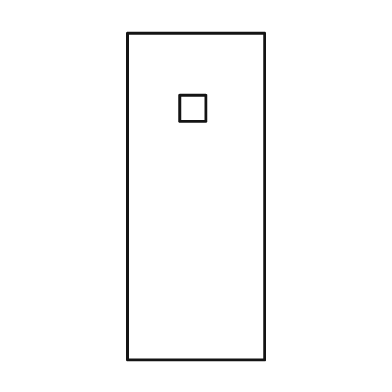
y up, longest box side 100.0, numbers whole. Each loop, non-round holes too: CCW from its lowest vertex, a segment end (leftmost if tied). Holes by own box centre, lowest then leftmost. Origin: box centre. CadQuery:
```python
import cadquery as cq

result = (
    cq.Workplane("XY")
    .moveTo(-21.0, -50.0)
    .lineTo(21.0, -50.0)
    .lineTo(21.0, 50.0)
    .lineTo(-21.0, 50.0)
    .close()
    .moveTo(-5.0, 23.0)
    .lineTo(3.0, 23.0)
    .lineTo(3.0, 31.0)
    .lineTo(-5.0, 31.0)
    .close()
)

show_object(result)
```